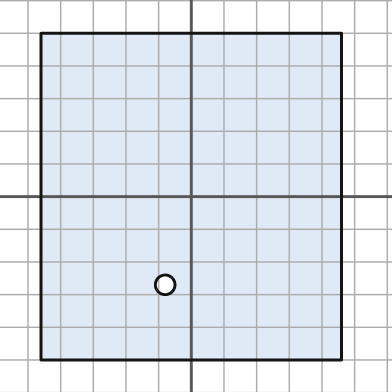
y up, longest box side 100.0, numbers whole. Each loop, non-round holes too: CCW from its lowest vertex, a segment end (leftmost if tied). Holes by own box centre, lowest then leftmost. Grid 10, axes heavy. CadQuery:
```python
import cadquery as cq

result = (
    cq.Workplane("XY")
    .moveTo(-46.0, -50.0)
    .lineTo(46.0, -50.0)
    .lineTo(46.0, 50.0)
    .lineTo(-46.0, 50.0)
    .close()
    .moveTo(-8.0, -27.0)
    .circle(3.0)
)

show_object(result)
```